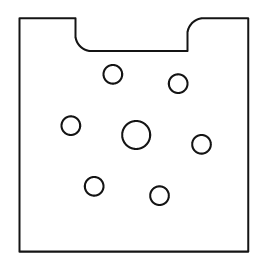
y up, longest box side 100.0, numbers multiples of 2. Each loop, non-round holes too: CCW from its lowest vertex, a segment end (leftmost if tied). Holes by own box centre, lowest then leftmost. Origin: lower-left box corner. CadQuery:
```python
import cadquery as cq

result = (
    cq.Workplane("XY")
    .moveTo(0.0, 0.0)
    .lineTo(98.0, 0.0)
    .lineTo(98.0, 100.0)
    .lineTo(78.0, 100.0)
    .threePointArc((74.0, 98.0), (72.0, 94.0))
    .lineTo(72.0, 86.0)
    .lineTo(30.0, 86.0)
    .threePointArc((26.0, 88.0), (24.0, 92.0))
    .lineTo(24.0, 100.0)
    .lineTo(0.0, 100.0)
    .close()
    .moveTo(60.0, 24.0)
    .circle(4.0)
    .moveTo(32.0, 28.0)
    .circle(4.0)
    .moveTo(78.0, 46.0)
    .circle(4.0)
    .moveTo(50.0, 50.0)
    .circle(6.0)
    .moveTo(22.0, 54.0)
    .circle(4.0)
    .moveTo(68.0, 72.0)
    .circle(4.0)
    .moveTo(40.0, 76.0)
    .circle(4.0)
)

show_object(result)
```